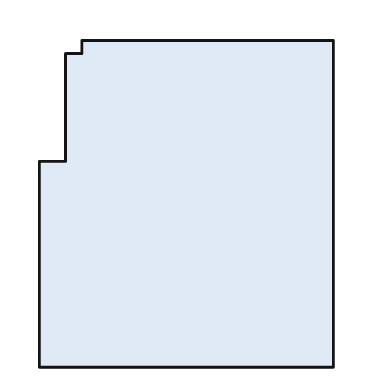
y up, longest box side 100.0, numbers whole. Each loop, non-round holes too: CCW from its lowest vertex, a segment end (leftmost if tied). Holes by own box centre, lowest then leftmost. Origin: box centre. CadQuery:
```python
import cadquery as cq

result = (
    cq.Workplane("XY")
    .moveTo(-45.0, -50.0)
    .lineTo(45.0, -50.0)
    .lineTo(45.0, 50.0)
    .lineTo(-32.0, 50.0)
    .lineTo(-32.0, 46.0)
    .lineTo(-37.0, 46.0)
    .lineTo(-37.0, 13.0)
    .lineTo(-45.0, 13.0)
    .close()
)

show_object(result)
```